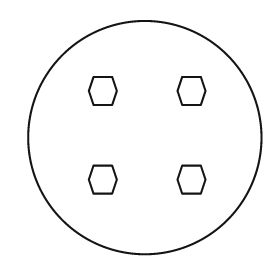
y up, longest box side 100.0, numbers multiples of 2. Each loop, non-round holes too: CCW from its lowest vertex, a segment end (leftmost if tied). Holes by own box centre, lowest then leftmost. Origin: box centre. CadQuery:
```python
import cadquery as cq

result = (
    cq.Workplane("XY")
    .moveTo(0.0, 0.0)
    .circle(50.0)
    .moveTo(-22.0, -24.0)
    .lineTo(-14.0, -24.0)
    .lineTo(-12.0, -18.0)
    .lineTo(-14.0, -12.0)
    .lineTo(-22.0, -12.0)
    .lineTo(-24.0, -18.0)
    .close()
    .moveTo(16.0, -24.0)
    .lineTo(24.0, -24.0)
    .lineTo(26.0, -18.0)
    .lineTo(24.0, -12.0)
    .lineTo(16.0, -12.0)
    .lineTo(14.0, -18.0)
    .close()
    .moveTo(-22.0, 14.0)
    .lineTo(-14.0, 14.0)
    .lineTo(-12.0, 20.0)
    .lineTo(-14.0, 26.0)
    .lineTo(-22.0, 26.0)
    .lineTo(-24.0, 20.0)
    .close()
    .moveTo(16.0, 14.0)
    .lineTo(24.0, 14.0)
    .lineTo(26.0, 20.0)
    .lineTo(24.0, 26.0)
    .lineTo(16.0, 26.0)
    .lineTo(14.0, 20.0)
    .close()
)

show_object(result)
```